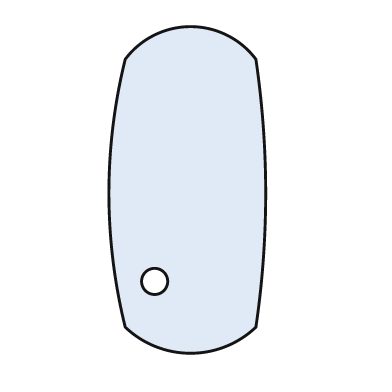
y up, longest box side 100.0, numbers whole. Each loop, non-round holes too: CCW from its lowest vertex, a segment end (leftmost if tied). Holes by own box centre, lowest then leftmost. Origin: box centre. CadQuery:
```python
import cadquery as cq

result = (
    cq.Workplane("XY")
    .moveTo(-19.0, -42.0)
    .threePointArc((1.0, -50.0), (21.0, -42.0))
    .threePointArc((24.0, -1.0), (21.0, 40.0))
    .threePointArc((1.0, 50.0), (-19.0, 40.0))
    .threePointArc((-24.0, -1.0), (-19.0, -42.0))
    .close()
    .moveTo(-10.0, -28.0)
    .circle(4.0)
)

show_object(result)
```